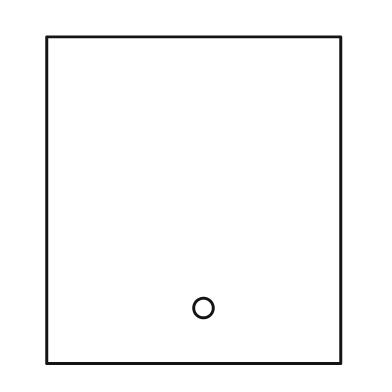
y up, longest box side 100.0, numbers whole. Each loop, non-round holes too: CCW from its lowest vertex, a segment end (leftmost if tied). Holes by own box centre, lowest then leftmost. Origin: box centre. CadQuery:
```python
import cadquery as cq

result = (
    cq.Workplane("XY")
    .moveTo(-45.0, -50.0)
    .lineTo(45.0, -50.0)
    .lineTo(45.0, 50.0)
    .lineTo(-45.0, 50.0)
    .close()
    .moveTo(3.0, -33.0)
    .circle(3.0)
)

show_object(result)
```